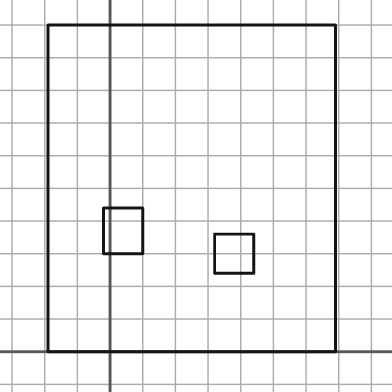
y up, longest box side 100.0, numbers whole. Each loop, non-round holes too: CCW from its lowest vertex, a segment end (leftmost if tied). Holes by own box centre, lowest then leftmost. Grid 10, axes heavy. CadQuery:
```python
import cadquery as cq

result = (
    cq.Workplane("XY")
    .moveTo(-19.0, 0.0)
    .lineTo(69.0, 0.0)
    .lineTo(69.0, 100.0)
    .lineTo(-19.0, 100.0)
    .close()
    .moveTo(32.0, 24.0)
    .lineTo(44.0, 24.0)
    .lineTo(44.0, 36.0)
    .lineTo(32.0, 36.0)
    .close()
    .moveTo(-2.0, 30.0)
    .lineTo(10.0, 30.0)
    .lineTo(10.0, 44.0)
    .lineTo(-2.0, 44.0)
    .close()
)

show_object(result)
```